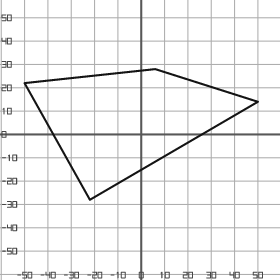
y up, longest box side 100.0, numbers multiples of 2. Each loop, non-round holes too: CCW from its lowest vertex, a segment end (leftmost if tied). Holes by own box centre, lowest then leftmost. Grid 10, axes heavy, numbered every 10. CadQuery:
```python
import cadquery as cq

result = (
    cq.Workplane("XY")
    .moveTo(-22.0, -28.0)
    .lineTo(50.0, 14.0)
    .lineTo(6.0, 28.0)
    .lineTo(-50.0, 22.0)
    .close()
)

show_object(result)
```